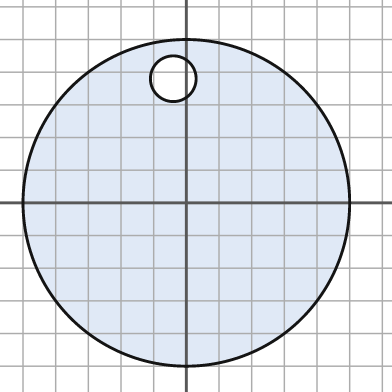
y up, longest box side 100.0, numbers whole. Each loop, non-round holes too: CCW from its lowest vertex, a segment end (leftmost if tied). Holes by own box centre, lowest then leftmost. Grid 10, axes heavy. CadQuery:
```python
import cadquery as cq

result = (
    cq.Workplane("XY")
    .moveTo(0.0, 0.0)
    .circle(50.0)
    .moveTo(-4.0, 38.0)
    .circle(7.0)
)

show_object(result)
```